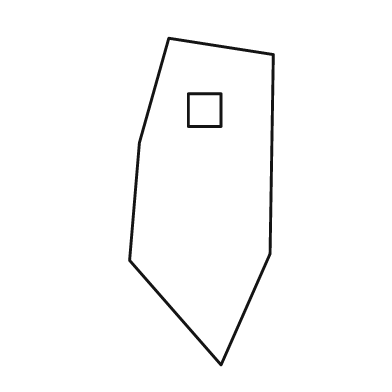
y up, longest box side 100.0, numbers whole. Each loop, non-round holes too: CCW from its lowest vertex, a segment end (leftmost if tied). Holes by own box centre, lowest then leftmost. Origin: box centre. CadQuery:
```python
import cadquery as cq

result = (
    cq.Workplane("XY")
    .moveTo(6.0, -50.0)
    .lineTo(21.0, -16.0)
    .lineTo(22.0, 45.0)
    .lineTo(-10.0, 50.0)
    .lineTo(-19.0, 18.0)
    .lineTo(-22.0, -18.0)
    .close()
    .moveTo(-4.0, 23.0)
    .lineTo(6.0, 23.0)
    .lineTo(6.0, 33.0)
    .lineTo(-4.0, 33.0)
    .close()
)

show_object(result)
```